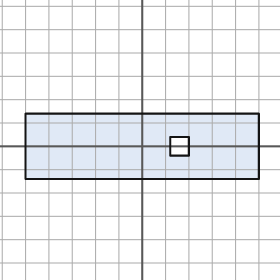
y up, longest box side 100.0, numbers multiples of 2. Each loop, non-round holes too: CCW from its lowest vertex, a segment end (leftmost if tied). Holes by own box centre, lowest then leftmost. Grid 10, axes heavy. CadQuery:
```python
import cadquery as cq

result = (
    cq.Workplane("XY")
    .moveTo(-50.0, -14.0)
    .lineTo(50.0, -14.0)
    .lineTo(50.0, 14.0)
    .lineTo(-50.0, 14.0)
    .close()
    .moveTo(12.0, -4.0)
    .lineTo(20.0, -4.0)
    .lineTo(20.0, 4.0)
    .lineTo(12.0, 4.0)
    .close()
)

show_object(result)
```